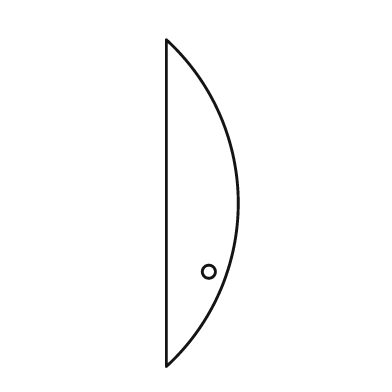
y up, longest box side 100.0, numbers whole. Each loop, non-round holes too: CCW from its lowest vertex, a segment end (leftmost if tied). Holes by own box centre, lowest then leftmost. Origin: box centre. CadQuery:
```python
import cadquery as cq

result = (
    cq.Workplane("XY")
    .moveTo(-11.0, -50.0)
    .threePointArc((11.0, 0.0), (-11.0, 50.0))
    .close()
    .moveTo(2.0, -21.0)
    .circle(2.0)
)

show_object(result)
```